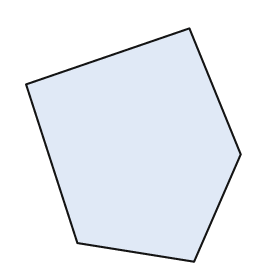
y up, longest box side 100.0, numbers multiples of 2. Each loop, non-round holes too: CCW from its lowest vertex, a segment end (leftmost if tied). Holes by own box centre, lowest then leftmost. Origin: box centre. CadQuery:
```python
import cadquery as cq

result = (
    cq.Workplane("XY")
    .moveTo(26.0, -50.0)
    .lineTo(46.0, -4.0)
    .lineTo(24.0, 50.0)
    .lineTo(-46.0, 26.0)
    .lineTo(-24.0, -42.0)
    .close()
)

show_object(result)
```